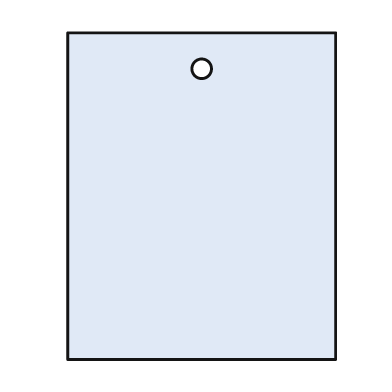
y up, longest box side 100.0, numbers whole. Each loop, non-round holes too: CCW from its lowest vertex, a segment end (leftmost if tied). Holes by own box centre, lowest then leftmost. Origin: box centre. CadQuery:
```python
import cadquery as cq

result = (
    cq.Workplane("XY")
    .moveTo(-41.0, -50.0)
    .lineTo(41.0, -50.0)
    .lineTo(41.0, 50.0)
    .lineTo(-41.0, 50.0)
    .close()
    .moveTo(0.0, 39.0)
    .circle(3.0)
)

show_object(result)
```